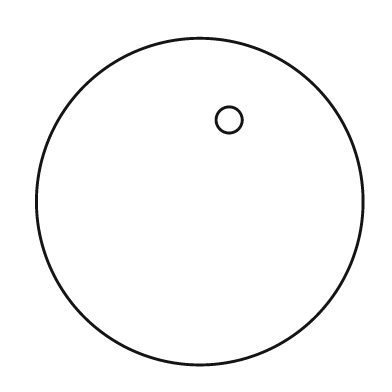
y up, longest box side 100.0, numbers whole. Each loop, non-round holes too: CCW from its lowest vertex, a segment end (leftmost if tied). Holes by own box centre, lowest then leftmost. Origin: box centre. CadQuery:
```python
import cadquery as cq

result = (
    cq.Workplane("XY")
    .moveTo(0.0, 0.0)
    .circle(50.0)
    .moveTo(9.0, 25.0)
    .circle(4.0)
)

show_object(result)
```